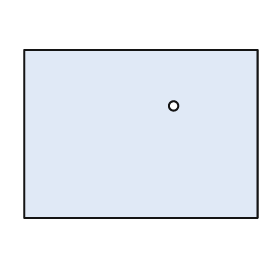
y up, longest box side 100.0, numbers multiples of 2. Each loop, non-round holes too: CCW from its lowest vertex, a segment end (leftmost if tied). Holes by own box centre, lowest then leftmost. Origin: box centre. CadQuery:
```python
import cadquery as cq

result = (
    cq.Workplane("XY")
    .moveTo(-50.0, -36.0)
    .lineTo(50.0, -36.0)
    .lineTo(50.0, 36.0)
    .lineTo(-50.0, 36.0)
    .close()
    .moveTo(14.0, 12.0)
    .circle(2.0)
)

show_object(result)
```